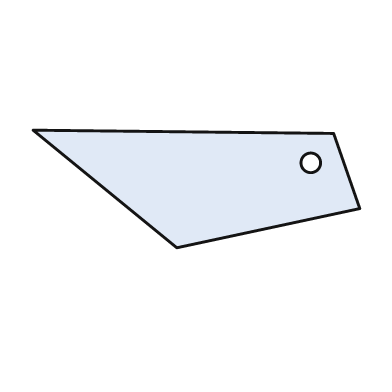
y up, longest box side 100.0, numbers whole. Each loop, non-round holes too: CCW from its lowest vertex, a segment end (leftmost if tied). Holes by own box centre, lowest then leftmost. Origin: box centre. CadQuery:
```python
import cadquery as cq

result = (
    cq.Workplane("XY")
    .moveTo(-6.0, -18.0)
    .lineTo(50.0, -6.0)
    .lineTo(42.0, 17.0)
    .lineTo(-50.0, 18.0)
    .close()
    .moveTo(35.0, 8.0)
    .circle(3.0)
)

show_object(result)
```